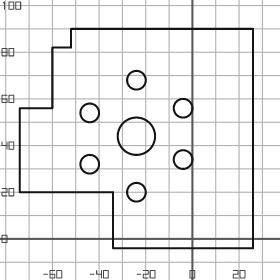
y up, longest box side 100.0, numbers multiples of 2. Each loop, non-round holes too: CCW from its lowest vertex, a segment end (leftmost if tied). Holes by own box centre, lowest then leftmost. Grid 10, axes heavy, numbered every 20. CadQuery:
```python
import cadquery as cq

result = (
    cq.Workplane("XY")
    .moveTo(-34.0, -4.0)
    .lineTo(26.0, -4.0)
    .lineTo(26.0, 90.0)
    .lineTo(-52.0, 90.0)
    .lineTo(-52.0, 82.0)
    .lineTo(-60.0, 82.0)
    .lineTo(-60.0, 56.0)
    .lineTo(-74.0, 56.0)
    .lineTo(-74.0, 20.0)
    .lineTo(-34.0, 20.0)
    .close()
    .moveTo(-24.0, 20.0)
    .circle(4.0)
    .moveTo(-44.0, 32.0)
    .circle(4.0)
    .moveTo(-4.0, 34.0)
    .circle(4.0)
    .moveTo(-24.0, 44.0)
    .circle(8.0)
    .moveTo(-44.0, 54.0)
    .circle(4.0)
    .moveTo(-4.0, 56.0)
    .circle(4.0)
    .moveTo(-24.0, 68.0)
    .circle(4.0)
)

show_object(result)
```